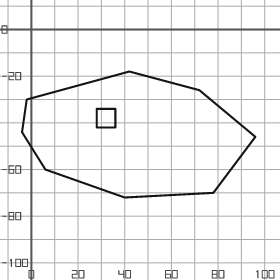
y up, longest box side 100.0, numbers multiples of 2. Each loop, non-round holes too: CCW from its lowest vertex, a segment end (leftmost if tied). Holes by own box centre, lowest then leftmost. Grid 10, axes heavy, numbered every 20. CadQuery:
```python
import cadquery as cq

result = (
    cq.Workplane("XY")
    .moveTo(40.0, -72.0)
    .lineTo(78.0, -70.0)
    .lineTo(96.0, -46.0)
    .lineTo(72.0, -26.0)
    .lineTo(42.0, -18.0)
    .lineTo(-2.0, -30.0)
    .lineTo(-4.0, -44.0)
    .lineTo(6.0, -60.0)
    .close()
    .moveTo(28.0, -42.0)
    .lineTo(36.0, -42.0)
    .lineTo(36.0, -34.0)
    .lineTo(28.0, -34.0)
    .close()
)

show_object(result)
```